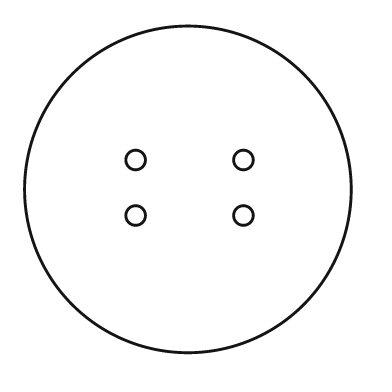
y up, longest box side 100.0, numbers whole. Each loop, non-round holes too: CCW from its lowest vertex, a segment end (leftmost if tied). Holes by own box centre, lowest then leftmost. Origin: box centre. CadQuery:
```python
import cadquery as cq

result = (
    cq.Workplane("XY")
    .moveTo(0.0, 0.0)
    .circle(50.0)
    .moveTo(-16.0, -8.0)
    .circle(3.0)
    .moveTo(17.0, -8.0)
    .circle(3.0)
    .moveTo(-16.0, 9.0)
    .circle(3.0)
    .moveTo(17.0, 9.0)
    .circle(3.0)
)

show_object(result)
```